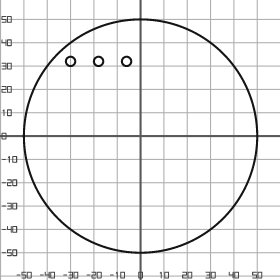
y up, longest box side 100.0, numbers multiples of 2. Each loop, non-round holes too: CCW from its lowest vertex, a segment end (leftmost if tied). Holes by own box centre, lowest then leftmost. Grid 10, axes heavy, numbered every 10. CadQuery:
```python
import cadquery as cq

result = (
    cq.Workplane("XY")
    .moveTo(0.0, 0.0)
    .circle(50.0)
    .moveTo(-30.0, 32.0)
    .circle(2.0)
    .moveTo(-18.0, 32.0)
    .circle(2.0)
    .moveTo(-6.0, 32.0)
    .circle(2.0)
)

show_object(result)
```